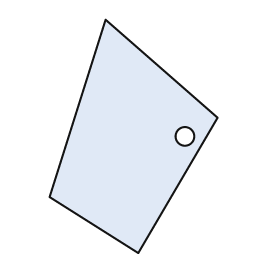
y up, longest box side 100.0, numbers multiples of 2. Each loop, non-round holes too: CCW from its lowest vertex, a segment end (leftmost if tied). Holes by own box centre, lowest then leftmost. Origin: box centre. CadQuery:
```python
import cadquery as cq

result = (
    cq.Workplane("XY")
    .moveTo(2.0, -50.0)
    .lineTo(36.0, 8.0)
    .lineTo(-12.0, 50.0)
    .lineTo(-36.0, -26.0)
    .close()
    .moveTo(22.0, 0.0)
    .circle(4.0)
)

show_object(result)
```